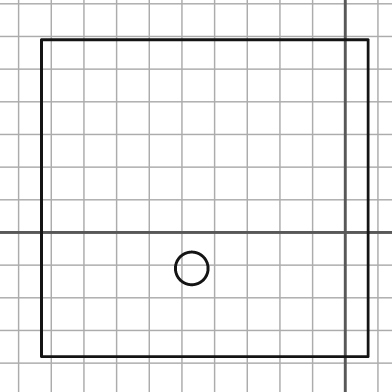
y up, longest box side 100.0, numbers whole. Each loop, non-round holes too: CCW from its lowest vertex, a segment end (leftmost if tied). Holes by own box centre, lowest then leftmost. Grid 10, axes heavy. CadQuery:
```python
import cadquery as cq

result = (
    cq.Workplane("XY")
    .moveTo(-93.0, -38.0)
    .lineTo(7.0, -38.0)
    .lineTo(7.0, 59.0)
    .lineTo(-93.0, 59.0)
    .close()
    .moveTo(-47.0, -11.0)
    .circle(5.0)
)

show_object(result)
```